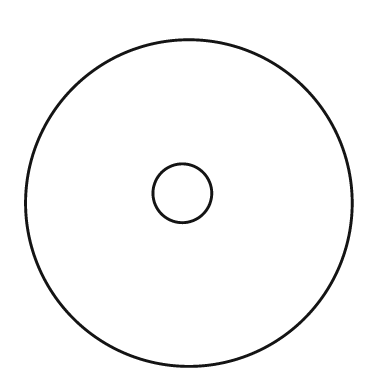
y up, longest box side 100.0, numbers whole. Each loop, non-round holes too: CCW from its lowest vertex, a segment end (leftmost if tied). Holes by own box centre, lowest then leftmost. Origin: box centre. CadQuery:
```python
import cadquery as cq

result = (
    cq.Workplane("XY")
    .moveTo(0.0, 0.0)
    .circle(50.0)
    .moveTo(-2.0, 3.0)
    .circle(9.0)
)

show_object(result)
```